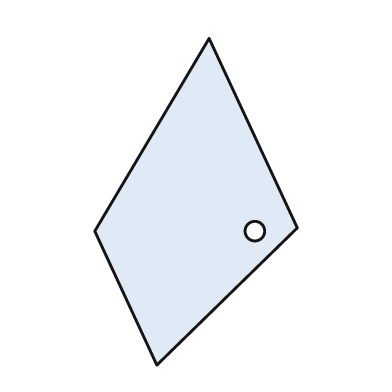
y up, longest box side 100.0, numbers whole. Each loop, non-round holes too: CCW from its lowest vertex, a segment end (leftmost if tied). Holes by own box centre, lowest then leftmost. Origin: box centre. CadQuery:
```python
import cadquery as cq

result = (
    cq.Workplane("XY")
    .moveTo(-12.0, -50.0)
    .lineTo(31.0, -8.0)
    .lineTo(4.0, 50.0)
    .lineTo(-31.0, -9.0)
    .close()
    .moveTo(18.0, -9.0)
    .circle(3.0)
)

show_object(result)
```